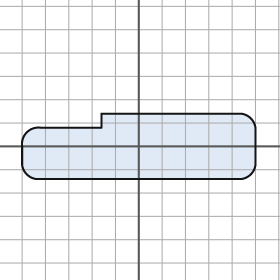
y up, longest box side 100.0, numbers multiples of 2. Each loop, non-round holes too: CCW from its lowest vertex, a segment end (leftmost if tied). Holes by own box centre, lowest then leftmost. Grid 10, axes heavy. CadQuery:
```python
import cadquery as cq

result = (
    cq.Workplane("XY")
    .moveTo(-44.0, -14.0)
    .lineTo(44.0, -14.0)
    .threePointArc((48.0, -12.0), (50.0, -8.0))
    .lineTo(50.0, 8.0)
    .threePointArc((48.0, 12.0), (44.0, 14.0))
    .lineTo(-16.0, 14.0)
    .lineTo(-16.0, 8.0)
    .lineTo(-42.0, 8.0)
    .threePointArc((-48.0, 6.0), (-50.0, 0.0))
    .lineTo(-50.0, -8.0)
    .threePointArc((-48.0, -12.0), (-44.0, -14.0))
    .close()
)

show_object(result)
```